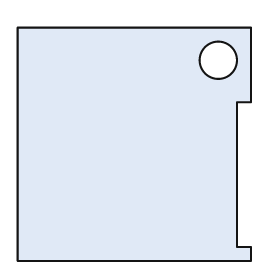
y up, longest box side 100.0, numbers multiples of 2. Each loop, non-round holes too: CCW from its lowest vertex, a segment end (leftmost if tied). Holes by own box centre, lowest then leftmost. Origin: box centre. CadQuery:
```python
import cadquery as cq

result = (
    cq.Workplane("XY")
    .moveTo(-50.0, -50.0)
    .lineTo(50.0, -50.0)
    .lineTo(50.0, -44.0)
    .lineTo(44.0, -44.0)
    .lineTo(44.0, 18.0)
    .lineTo(50.0, 18.0)
    .lineTo(50.0, 50.0)
    .lineTo(-50.0, 50.0)
    .close()
    .moveTo(36.0, 36.0)
    .circle(8.0)
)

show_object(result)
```